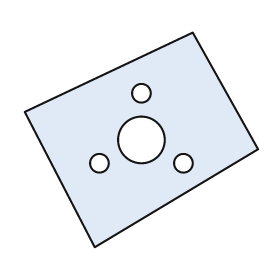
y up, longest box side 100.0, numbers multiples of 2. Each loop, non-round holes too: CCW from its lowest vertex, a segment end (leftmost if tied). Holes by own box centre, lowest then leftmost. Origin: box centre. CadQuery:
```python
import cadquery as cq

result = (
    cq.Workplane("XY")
    .moveTo(-20.0, -46.0)
    .lineTo(50.0, -4.0)
    .lineTo(22.0, 46.0)
    .lineTo(-50.0, 12.0)
    .close()
    .moveTo(-18.0, -10.0)
    .circle(4.0)
    .moveTo(18.0, -10.0)
    .circle(4.0)
    .moveTo(0.0, 0.0)
    .circle(10.0)
    .moveTo(0.0, 20.0)
    .circle(4.0)
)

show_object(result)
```